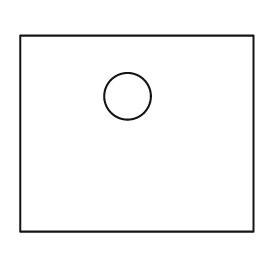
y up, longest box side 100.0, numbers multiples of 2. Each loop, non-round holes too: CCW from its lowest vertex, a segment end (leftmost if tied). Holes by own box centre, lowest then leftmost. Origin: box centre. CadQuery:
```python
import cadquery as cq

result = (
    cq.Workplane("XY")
    .moveTo(-50.0, -42.0)
    .lineTo(50.0, -42.0)
    .lineTo(50.0, 42.0)
    .lineTo(-50.0, 42.0)
    .close()
    .moveTo(-4.0, 16.0)
    .circle(10.0)
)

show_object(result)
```